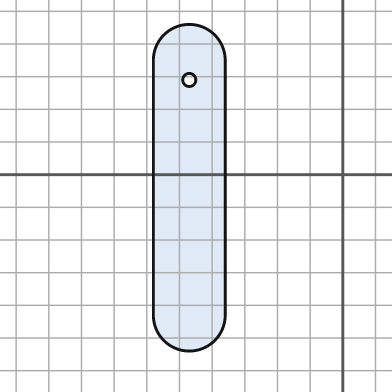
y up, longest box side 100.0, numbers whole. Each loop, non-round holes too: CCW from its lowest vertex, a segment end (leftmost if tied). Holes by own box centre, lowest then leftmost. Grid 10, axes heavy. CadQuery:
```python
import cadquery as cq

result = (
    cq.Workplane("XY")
    .moveTo(-58.0, -43.0)
    .threePointArc((-47.0, -54.0), (-36.0, -43.0))
    .lineTo(-36.0, 35.0)
    .threePointArc((-47.0, 46.0), (-58.0, 35.0))
    .close()
    .moveTo(-47.0, 29.0)
    .circle(2.0)
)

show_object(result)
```